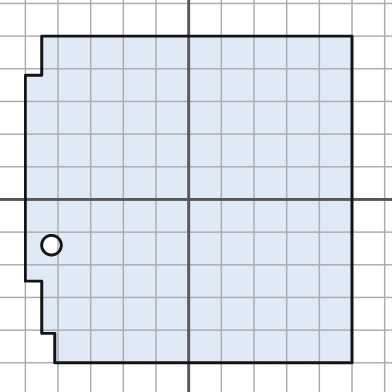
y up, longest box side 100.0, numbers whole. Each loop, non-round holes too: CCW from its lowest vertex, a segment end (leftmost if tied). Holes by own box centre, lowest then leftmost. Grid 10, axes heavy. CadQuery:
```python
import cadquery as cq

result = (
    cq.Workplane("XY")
    .moveTo(-41.0, -50.0)
    .lineTo(50.0, -50.0)
    .lineTo(50.0, 50.0)
    .lineTo(-45.0, 50.0)
    .lineTo(-45.0, 38.0)
    .lineTo(-50.0, 38.0)
    .lineTo(-50.0, -25.0)
    .lineTo(-45.0, -25.0)
    .lineTo(-45.0, -41.0)
    .lineTo(-41.0, -41.0)
    .close()
    .moveTo(-42.0, -14.0)
    .circle(3.0)
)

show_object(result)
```